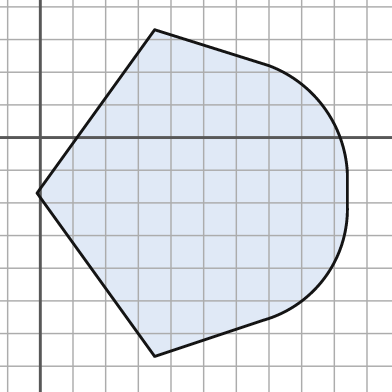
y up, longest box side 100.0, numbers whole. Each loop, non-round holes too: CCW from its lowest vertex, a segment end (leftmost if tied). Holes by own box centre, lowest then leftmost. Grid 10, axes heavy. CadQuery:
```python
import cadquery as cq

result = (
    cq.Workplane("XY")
    .moveTo(35.0, -67.0)
    .lineTo(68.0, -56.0)
    .threePointArc((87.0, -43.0), (94.0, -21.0))
    .lineTo(94.0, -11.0)
    .threePointArc((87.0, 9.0), (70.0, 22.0))
    .lineTo(35.0, 33.0)
    .lineTo(-1.0, -17.0)
    .close()
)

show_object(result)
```